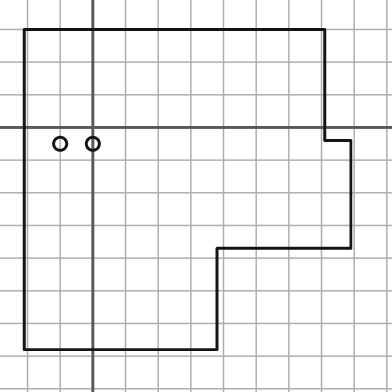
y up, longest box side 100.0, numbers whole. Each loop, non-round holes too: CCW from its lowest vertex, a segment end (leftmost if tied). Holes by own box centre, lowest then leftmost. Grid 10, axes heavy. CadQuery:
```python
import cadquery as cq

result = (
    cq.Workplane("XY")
    .moveTo(-21.0, -68.0)
    .lineTo(38.0, -68.0)
    .lineTo(38.0, -37.0)
    .lineTo(79.0, -37.0)
    .lineTo(79.0, -4.0)
    .lineTo(71.0, -4.0)
    .lineTo(71.0, 30.0)
    .lineTo(-21.0, 30.0)
    .close()
    .moveTo(-10.0, -5.0)
    .circle(2.0)
    .moveTo(0.0, -5.0)
    .circle(2.0)
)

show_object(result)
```